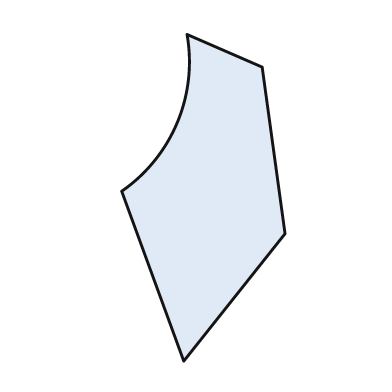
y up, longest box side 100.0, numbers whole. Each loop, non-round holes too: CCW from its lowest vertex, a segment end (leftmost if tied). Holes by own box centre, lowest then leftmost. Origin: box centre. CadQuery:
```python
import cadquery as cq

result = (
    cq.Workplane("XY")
    .moveTo(-6.0, -50.0)
    .lineTo(25.0, -11.0)
    .lineTo(18.0, 40.0)
    .lineTo(-5.0, 50.0)
    .threePointArc((-8.0, 23.0), (-25.0, 2.0))
    .close()
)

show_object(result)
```